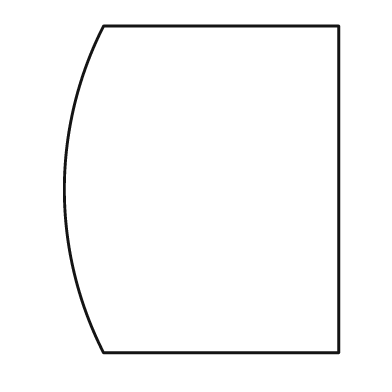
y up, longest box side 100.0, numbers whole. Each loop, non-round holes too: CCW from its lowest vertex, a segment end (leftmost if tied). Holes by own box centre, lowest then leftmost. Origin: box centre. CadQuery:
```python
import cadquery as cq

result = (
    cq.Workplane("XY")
    .moveTo(-30.0, -50.0)
    .lineTo(42.0, -50.0)
    .lineTo(42.0, 50.0)
    .lineTo(-30.0, 50.0)
    .threePointArc((-42.0, 0.0), (-30.0, -50.0))
    .close()
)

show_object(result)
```